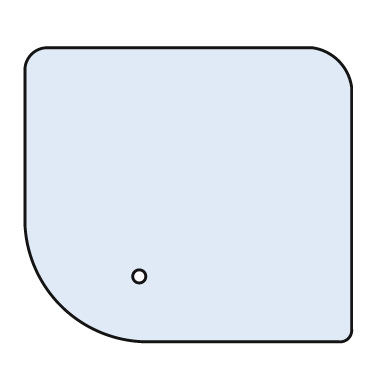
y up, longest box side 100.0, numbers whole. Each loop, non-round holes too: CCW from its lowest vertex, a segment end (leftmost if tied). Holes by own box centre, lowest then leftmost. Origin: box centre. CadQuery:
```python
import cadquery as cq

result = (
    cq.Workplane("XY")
    .moveTo(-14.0, -45.0)
    .lineTo(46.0, -45.0)
    .threePointArc((49.0, -44.0), (50.0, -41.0))
    .lineTo(50.0, 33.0)
    .threePointArc((46.0, 41.0), (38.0, 45.0))
    .lineTo(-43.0, 45.0)
    .threePointArc((-48.0, 43.0), (-50.0, 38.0))
    .lineTo(-50.0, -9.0)
    .threePointArc((-39.0, -34.0), (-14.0, -45.0))
    .close()
    .moveTo(-15.0, -25.0)
    .circle(2.0)
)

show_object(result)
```